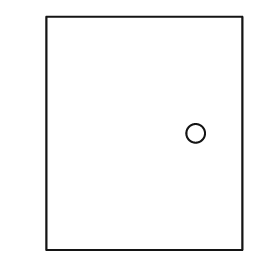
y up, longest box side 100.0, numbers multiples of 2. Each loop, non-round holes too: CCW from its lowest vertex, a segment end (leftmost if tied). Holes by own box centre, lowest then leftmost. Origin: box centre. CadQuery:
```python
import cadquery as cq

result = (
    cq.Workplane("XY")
    .moveTo(-42.0, -50.0)
    .lineTo(42.0, -50.0)
    .lineTo(42.0, 50.0)
    .lineTo(-42.0, 50.0)
    .close()
    .moveTo(22.0, 0.0)
    .circle(4.0)
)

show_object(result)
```